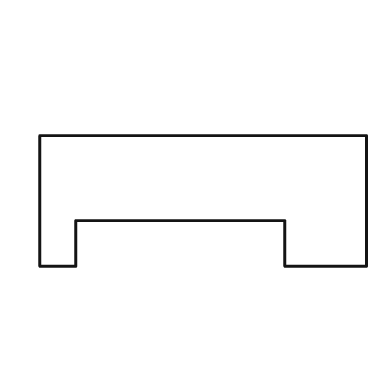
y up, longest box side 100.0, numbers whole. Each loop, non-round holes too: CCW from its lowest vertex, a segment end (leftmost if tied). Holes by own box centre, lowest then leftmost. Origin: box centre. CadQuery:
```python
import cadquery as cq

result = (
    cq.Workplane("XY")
    .moveTo(-50.0, -20.0)
    .lineTo(-39.0, -20.0)
    .lineTo(-39.0, -6.0)
    .lineTo(25.0, -6.0)
    .lineTo(25.0, -20.0)
    .lineTo(50.0, -20.0)
    .lineTo(50.0, 20.0)
    .lineTo(-50.0, 20.0)
    .close()
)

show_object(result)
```